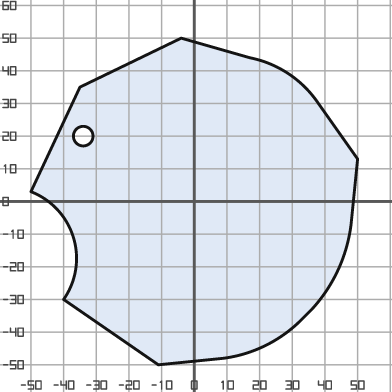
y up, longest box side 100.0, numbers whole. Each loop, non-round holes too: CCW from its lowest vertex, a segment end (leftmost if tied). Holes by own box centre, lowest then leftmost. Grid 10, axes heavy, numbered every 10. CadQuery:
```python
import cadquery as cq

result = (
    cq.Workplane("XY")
    .moveTo(-11.0, -50.0)
    .lineTo(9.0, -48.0)
    .threePointArc((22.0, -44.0), (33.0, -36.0))
    .lineTo(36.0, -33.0)
    .threePointArc((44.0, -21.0), (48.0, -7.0))
    .lineTo(50.0, 13.0)
    .lineTo(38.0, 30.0)
    .threePointArc((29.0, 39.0), (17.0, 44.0))
    .lineTo(-4.0, 50.0)
    .lineTo(-35.0, 35.0)
    .lineTo(-50.0, 3.0)
    .threePointArc((-37.0, -11.0), (-40.0, -30.0))
    .close()
    .moveTo(-34.0, 20.0)
    .circle(3.0)
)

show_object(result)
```